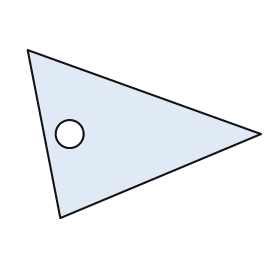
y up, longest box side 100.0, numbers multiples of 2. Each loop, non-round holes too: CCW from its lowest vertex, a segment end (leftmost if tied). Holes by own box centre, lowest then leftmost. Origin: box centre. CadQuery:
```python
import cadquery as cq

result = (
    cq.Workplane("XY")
    .moveTo(-36.0, -36.0)
    .lineTo(50.0, 0.0)
    .lineTo(-50.0, 36.0)
    .close()
    .moveTo(-32.0, 0.0)
    .circle(6.0)
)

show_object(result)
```